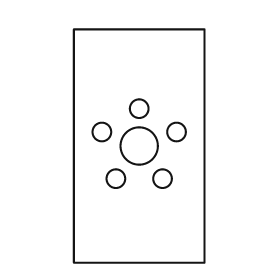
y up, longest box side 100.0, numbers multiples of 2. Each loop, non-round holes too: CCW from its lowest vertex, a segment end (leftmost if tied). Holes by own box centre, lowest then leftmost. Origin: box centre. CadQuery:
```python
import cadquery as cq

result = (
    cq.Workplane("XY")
    .moveTo(-28.0, -50.0)
    .lineTo(28.0, -50.0)
    .lineTo(28.0, 50.0)
    .lineTo(-28.0, 50.0)
    .close()
    .moveTo(-10.0, -14.0)
    .circle(4.0)
    .moveTo(10.0, -14.0)
    .circle(4.0)
    .moveTo(0.0, 0.0)
    .circle(8.0)
    .moveTo(-16.0, 6.0)
    .circle(4.0)
    .moveTo(16.0, 6.0)
    .circle(4.0)
    .moveTo(0.0, 16.0)
    .circle(4.0)
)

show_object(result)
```